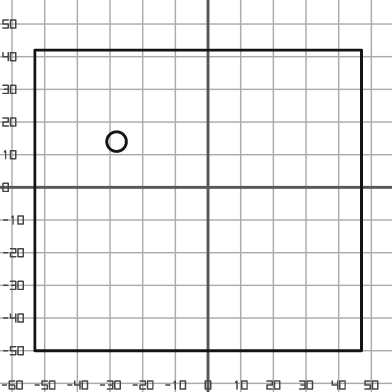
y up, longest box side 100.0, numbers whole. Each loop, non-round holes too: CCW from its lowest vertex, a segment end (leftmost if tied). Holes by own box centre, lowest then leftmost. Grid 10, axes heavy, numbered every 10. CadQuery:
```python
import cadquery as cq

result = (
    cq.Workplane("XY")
    .moveTo(-53.0, -50.0)
    .lineTo(47.0, -50.0)
    .lineTo(47.0, 42.0)
    .lineTo(-53.0, 42.0)
    .close()
    .moveTo(-28.0, 14.0)
    .circle(3.0)
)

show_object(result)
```